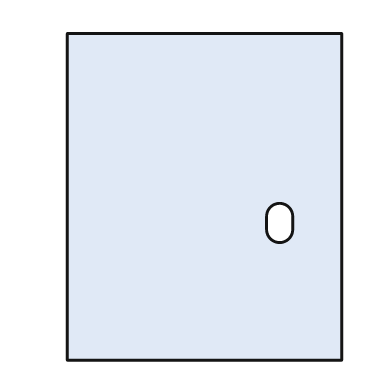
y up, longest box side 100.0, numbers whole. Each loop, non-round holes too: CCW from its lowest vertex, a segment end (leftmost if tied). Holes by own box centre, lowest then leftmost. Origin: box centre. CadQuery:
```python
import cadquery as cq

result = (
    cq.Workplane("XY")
    .moveTo(-42.0, -50.0)
    .lineTo(42.0, -50.0)
    .lineTo(42.0, 50.0)
    .lineTo(-42.0, 50.0)
    .close()
    .moveTo(19.0, -10.0)
    .threePointArc((23.0, -14.0), (27.0, -10.0))
    .lineTo(27.0, -6.0)
    .threePointArc((23.0, -2.0), (19.0, -6.0))
    .close()
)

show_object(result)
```